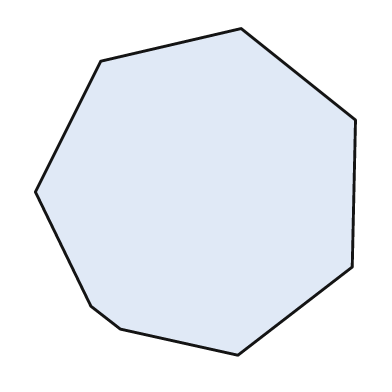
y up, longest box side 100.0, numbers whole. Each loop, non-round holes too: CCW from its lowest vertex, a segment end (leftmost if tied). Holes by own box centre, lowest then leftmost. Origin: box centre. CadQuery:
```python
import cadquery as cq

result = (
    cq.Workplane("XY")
    .moveTo(13.0, -50.0)
    .lineTo(48.0, -23.0)
    .lineTo(49.0, 22.0)
    .lineTo(14.0, 50.0)
    .lineTo(-29.0, 40.0)
    .lineTo(-49.0, 0.0)
    .lineTo(-32.0, -35.0)
    .lineTo(-23.0, -42.0)
    .close()
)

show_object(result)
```